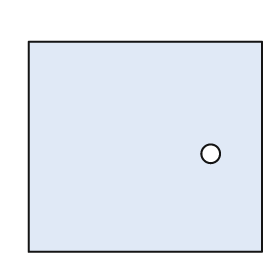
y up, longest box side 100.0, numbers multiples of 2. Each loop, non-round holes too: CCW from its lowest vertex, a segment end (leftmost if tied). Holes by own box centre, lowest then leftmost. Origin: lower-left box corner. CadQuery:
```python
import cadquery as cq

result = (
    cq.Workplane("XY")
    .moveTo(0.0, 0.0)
    .lineTo(100.0, 0.0)
    .lineTo(100.0, 90.0)
    .lineTo(0.0, 90.0)
    .close()
    .moveTo(78.0, 42.0)
    .circle(4.0)
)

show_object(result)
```